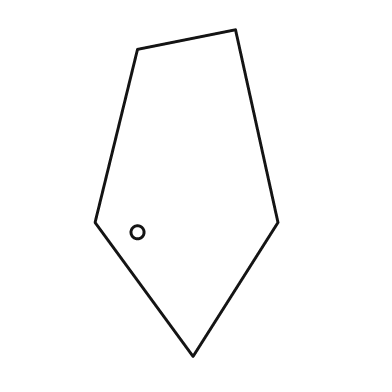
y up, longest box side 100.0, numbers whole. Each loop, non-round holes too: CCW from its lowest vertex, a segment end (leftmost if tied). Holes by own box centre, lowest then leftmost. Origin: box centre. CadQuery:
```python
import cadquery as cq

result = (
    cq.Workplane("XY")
    .moveTo(2.0, -50.0)
    .lineTo(28.0, -9.0)
    .lineTo(15.0, 50.0)
    .lineTo(-15.0, 44.0)
    .lineTo(-28.0, -9.0)
    .close()
    .moveTo(-15.0, -12.0)
    .circle(2.0)
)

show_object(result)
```